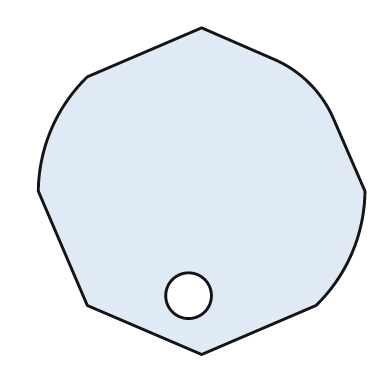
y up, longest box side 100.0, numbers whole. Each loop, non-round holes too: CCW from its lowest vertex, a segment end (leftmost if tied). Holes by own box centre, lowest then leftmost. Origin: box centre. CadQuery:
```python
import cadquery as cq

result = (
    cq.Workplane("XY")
    .moveTo(0.0, -50.0)
    .lineTo(35.0, -35.0)
    .threePointArc((46.0, -19.0), (50.0, 0.0))
    .lineTo(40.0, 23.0)
    .threePointArc((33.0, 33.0), (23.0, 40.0))
    .lineTo(0.0, 50.0)
    .lineTo(-35.0, 35.0)
    .threePointArc((-46.0, 19.0), (-50.0, 0.0))
    .lineTo(-35.0, -35.0)
    .close()
    .moveTo(-4.0, -32.0)
    .circle(7.0)
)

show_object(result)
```